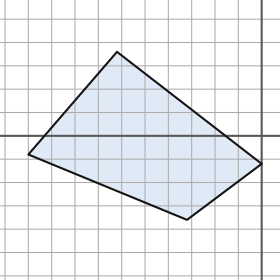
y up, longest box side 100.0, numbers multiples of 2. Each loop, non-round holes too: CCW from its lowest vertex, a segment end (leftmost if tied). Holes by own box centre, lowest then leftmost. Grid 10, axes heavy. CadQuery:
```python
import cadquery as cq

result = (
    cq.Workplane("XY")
    .moveTo(-32.0, -36.0)
    .lineTo(0.0, -12.0)
    .lineTo(-62.0, 36.0)
    .lineTo(-100.0, -8.0)
    .close()
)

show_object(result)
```